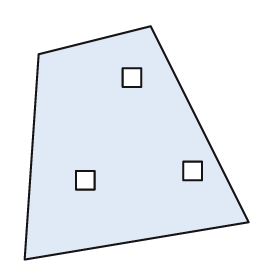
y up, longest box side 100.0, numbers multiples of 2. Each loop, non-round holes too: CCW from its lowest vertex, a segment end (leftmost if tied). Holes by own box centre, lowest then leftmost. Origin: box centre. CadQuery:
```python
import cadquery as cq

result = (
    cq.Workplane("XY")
    .moveTo(-48.0, -50.0)
    .lineTo(48.0, -34.0)
    .lineTo(6.0, 50.0)
    .lineTo(-42.0, 38.0)
    .close()
    .moveTo(-26.0, -20.0)
    .lineTo(-18.0, -20.0)
    .lineTo(-18.0, -12.0)
    .lineTo(-26.0, -12.0)
    .close()
    .moveTo(20.0, -16.0)
    .lineTo(28.0, -16.0)
    .lineTo(28.0, -8.0)
    .lineTo(20.0, -8.0)
    .close()
    .moveTo(-6.0, 24.0)
    .lineTo(2.0, 24.0)
    .lineTo(2.0, 32.0)
    .lineTo(-6.0, 32.0)
    .close()
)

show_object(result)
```